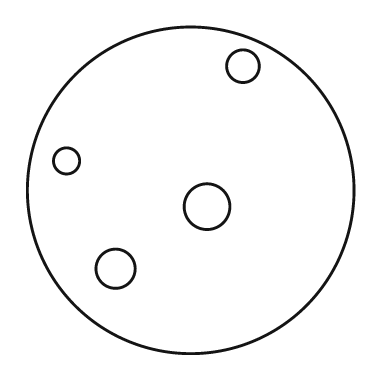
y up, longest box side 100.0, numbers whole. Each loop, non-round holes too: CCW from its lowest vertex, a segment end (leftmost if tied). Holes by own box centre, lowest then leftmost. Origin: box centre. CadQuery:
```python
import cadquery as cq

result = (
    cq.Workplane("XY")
    .moveTo(0.0, 0.0)
    .circle(50.0)
    .moveTo(-23.0, -24.0)
    .circle(6.0)
    .moveTo(5.0, -5.0)
    .circle(7.0)
    .moveTo(-38.0, 9.0)
    .circle(4.0)
    .moveTo(16.0, 38.0)
    .circle(5.0)
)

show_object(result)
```